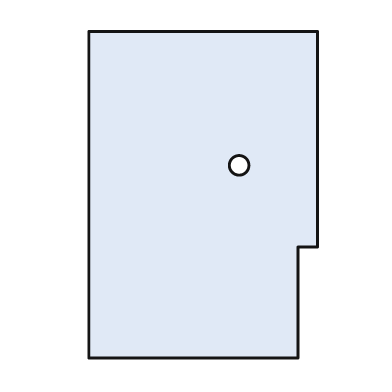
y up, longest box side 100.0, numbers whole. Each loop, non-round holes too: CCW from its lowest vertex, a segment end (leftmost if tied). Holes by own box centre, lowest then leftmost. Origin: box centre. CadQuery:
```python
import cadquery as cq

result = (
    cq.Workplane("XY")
    .moveTo(-35.0, -50.0)
    .lineTo(29.0, -50.0)
    .lineTo(29.0, -16.0)
    .lineTo(35.0, -16.0)
    .lineTo(35.0, 50.0)
    .lineTo(-35.0, 50.0)
    .close()
    .moveTo(11.0, 9.0)
    .circle(3.0)
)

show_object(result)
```